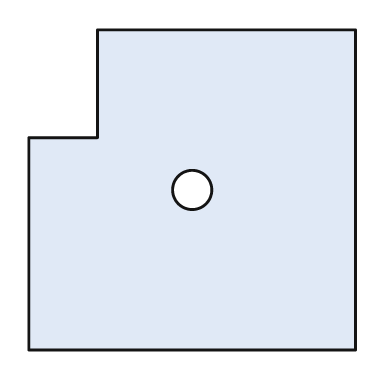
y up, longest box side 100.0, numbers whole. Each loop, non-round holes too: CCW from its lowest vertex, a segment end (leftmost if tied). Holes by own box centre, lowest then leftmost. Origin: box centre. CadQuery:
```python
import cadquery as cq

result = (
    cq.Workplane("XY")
    .moveTo(-50.0, -49.0)
    .lineTo(50.0, -49.0)
    .lineTo(50.0, 49.0)
    .lineTo(-29.0, 49.0)
    .lineTo(-29.0, 16.0)
    .lineTo(-50.0, 16.0)
    .close()
    .moveTo(0.0, 0.0)
    .circle(6.0)
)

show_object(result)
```